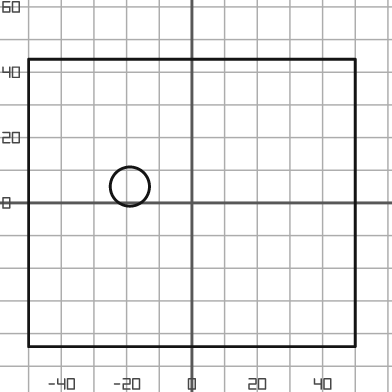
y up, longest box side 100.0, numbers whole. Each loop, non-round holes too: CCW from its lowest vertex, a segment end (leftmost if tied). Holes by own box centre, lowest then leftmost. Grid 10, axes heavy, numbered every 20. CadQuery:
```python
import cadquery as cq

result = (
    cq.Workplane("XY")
    .moveTo(-50.0, -44.0)
    .lineTo(50.0, -44.0)
    .lineTo(50.0, 44.0)
    .lineTo(-50.0, 44.0)
    .close()
    .moveTo(-19.0, 5.0)
    .circle(6.0)
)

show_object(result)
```